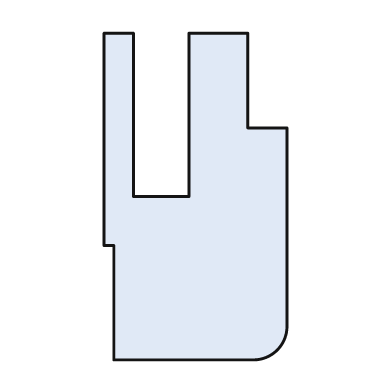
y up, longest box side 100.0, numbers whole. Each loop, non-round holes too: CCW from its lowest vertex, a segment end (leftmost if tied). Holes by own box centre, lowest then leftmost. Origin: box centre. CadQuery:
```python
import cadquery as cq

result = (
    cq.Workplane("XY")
    .moveTo(-25.0, -50.0)
    .lineTo(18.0, -50.0)
    .threePointArc((25.0, -47.0), (28.0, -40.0))
    .lineTo(28.0, 21.0)
    .lineTo(16.0, 21.0)
    .lineTo(16.0, 50.0)
    .lineTo(-2.0, 50.0)
    .lineTo(-2.0, 0.0)
    .lineTo(-19.0, 0.0)
    .lineTo(-19.0, 50.0)
    .lineTo(-28.0, 50.0)
    .lineTo(-28.0, -15.0)
    .lineTo(-25.0, -15.0)
    .close()
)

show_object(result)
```